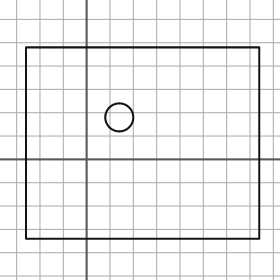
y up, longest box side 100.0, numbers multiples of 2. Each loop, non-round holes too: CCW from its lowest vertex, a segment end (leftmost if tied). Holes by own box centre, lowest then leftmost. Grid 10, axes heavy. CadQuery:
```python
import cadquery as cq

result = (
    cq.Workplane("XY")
    .moveTo(-26.0, -34.0)
    .lineTo(74.0, -34.0)
    .lineTo(74.0, 48.0)
    .lineTo(-26.0, 48.0)
    .close()
    .moveTo(14.0, 18.0)
    .circle(6.0)
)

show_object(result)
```